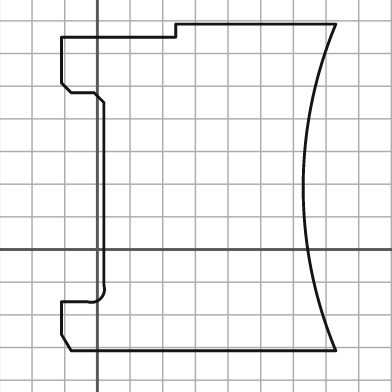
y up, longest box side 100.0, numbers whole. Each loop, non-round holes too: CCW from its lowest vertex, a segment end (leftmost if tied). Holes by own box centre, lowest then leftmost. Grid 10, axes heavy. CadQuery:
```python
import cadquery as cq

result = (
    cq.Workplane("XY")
    .moveTo(-8.0, -31.0)
    .lineTo(73.0, -31.0)
    .threePointArc((63.0, 19.0), (73.0, 69.0))
    .lineTo(24.0, 69.0)
    .lineTo(24.0, 65.0)
    .lineTo(-11.0, 65.0)
    .lineTo(-11.0, 51.0)
    .lineTo(-8.0, 48.0)
    .lineTo(-1.0, 48.0)
    .lineTo(2.0, 45.0)
    .lineTo(2.0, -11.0)
    .threePointArc((1.0, -15.0), (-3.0, -16.0))
    .lineTo(-11.0, -16.0)
    .lineTo(-11.0, -26.0)
    .close()
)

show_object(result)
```